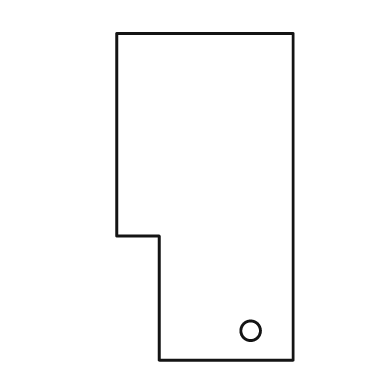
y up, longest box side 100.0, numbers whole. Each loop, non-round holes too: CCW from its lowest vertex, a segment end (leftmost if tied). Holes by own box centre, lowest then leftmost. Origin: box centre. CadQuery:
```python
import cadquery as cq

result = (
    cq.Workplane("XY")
    .moveTo(-14.0, -50.0)
    .lineTo(27.0, -50.0)
    .lineTo(27.0, 50.0)
    .lineTo(-27.0, 50.0)
    .lineTo(-27.0, -12.0)
    .lineTo(-14.0, -12.0)
    .close()
    .moveTo(14.0, -41.0)
    .circle(3.0)
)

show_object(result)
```